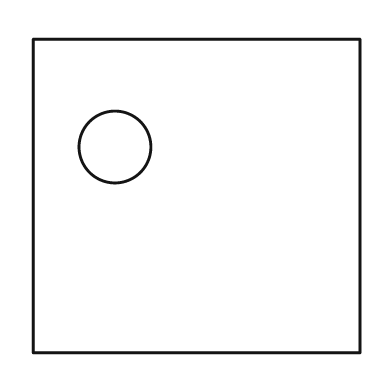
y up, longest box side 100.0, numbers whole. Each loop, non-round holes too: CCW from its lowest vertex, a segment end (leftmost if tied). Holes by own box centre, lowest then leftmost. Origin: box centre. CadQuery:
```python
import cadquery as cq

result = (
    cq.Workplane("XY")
    .moveTo(-50.0, -48.0)
    .lineTo(50.0, -48.0)
    .lineTo(50.0, 48.0)
    .lineTo(-50.0, 48.0)
    .close()
    .moveTo(-25.0, 15.0)
    .circle(11.0)
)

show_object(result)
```